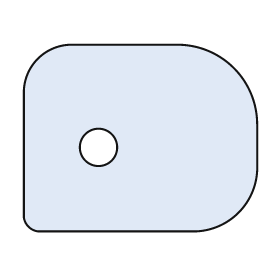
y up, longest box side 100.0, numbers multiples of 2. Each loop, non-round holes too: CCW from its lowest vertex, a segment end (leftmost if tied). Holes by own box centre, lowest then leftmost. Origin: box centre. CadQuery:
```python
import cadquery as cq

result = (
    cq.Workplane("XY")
    .moveTo(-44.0, -40.0)
    .lineTo(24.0, -40.0)
    .threePointArc((42.0, -32.0), (50.0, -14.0))
    .lineTo(50.0, 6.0)
    .threePointArc((40.0, 30.0), (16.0, 40.0))
    .lineTo(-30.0, 40.0)
    .threePointArc((-44.0, 34.0), (-50.0, 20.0))
    .lineTo(-50.0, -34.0)
    .threePointArc((-48.0, -38.0), (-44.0, -40.0))
    .close()
    .moveTo(-18.0, -4.0)
    .circle(8.0)
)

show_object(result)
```